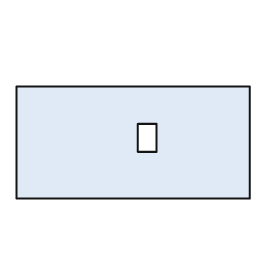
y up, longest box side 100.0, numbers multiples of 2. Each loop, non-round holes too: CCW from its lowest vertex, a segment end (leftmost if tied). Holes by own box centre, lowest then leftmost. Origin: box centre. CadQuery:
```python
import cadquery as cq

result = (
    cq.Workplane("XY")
    .moveTo(-50.0, -24.0)
    .lineTo(50.0, -24.0)
    .lineTo(50.0, 24.0)
    .lineTo(-50.0, 24.0)
    .close()
    .moveTo(2.0, -4.0)
    .lineTo(10.0, -4.0)
    .lineTo(10.0, 8.0)
    .lineTo(2.0, 8.0)
    .close()
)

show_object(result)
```